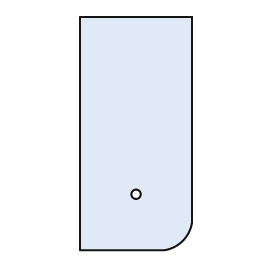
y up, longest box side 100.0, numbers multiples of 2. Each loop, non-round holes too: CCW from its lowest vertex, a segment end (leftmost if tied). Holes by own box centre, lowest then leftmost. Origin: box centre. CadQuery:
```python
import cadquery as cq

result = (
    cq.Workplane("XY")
    .moveTo(-24.0, -50.0)
    .lineTo(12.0, -50.0)
    .threePointArc((20.0, -46.0), (24.0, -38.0))
    .lineTo(24.0, 50.0)
    .lineTo(-24.0, 50.0)
    .close()
    .moveTo(0.0, -26.0)
    .circle(2.0)
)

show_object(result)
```